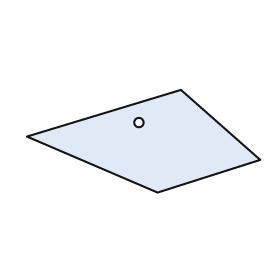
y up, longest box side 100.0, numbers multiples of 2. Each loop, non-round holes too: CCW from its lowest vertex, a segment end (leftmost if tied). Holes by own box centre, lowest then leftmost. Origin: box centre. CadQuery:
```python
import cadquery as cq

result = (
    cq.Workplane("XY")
    .moveTo(6.0, -22.0)
    .lineTo(50.0, -8.0)
    .lineTo(16.0, 22.0)
    .lineTo(-50.0, 2.0)
    .close()
    .moveTo(-2.0, 8.0)
    .circle(2.0)
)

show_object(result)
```